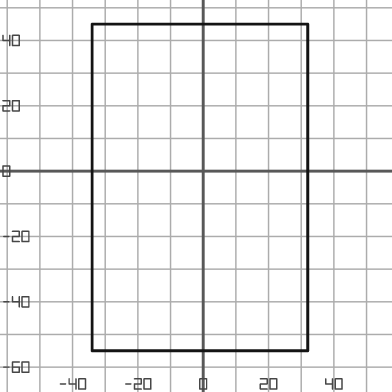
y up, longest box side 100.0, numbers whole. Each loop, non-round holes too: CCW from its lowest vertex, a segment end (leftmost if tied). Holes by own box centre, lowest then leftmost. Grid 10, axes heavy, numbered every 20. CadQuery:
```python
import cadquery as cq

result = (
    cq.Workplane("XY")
    .moveTo(-34.0, -55.0)
    .lineTo(32.0, -55.0)
    .lineTo(32.0, 45.0)
    .lineTo(-34.0, 45.0)
    .close()
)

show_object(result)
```